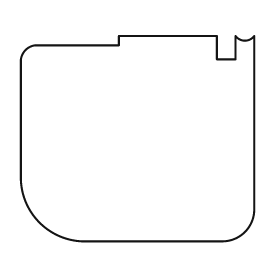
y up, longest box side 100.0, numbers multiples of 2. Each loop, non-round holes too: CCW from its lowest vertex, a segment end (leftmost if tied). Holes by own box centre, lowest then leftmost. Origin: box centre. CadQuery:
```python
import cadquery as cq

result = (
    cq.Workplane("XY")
    .moveTo(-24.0, -44.0)
    .lineTo(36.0, -44.0)
    .threePointArc((46.0, -40.0), (50.0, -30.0))
    .lineTo(50.0, 44.0)
    .threePointArc((46.0, 42.0), (42.0, 44.0))
    .lineTo(42.0, 34.0)
    .lineTo(34.0, 34.0)
    .lineTo(34.0, 44.0)
    .lineTo(-8.0, 44.0)
    .lineTo(-8.0, 40.0)
    .lineTo(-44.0, 40.0)
    .threePointArc((-48.0, 38.0), (-50.0, 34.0))
    .lineTo(-50.0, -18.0)
    .threePointArc((-42.0, -36.0), (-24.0, -44.0))
    .close()
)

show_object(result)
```